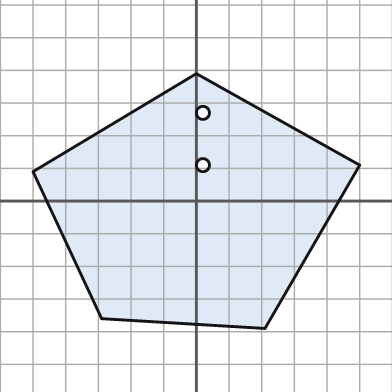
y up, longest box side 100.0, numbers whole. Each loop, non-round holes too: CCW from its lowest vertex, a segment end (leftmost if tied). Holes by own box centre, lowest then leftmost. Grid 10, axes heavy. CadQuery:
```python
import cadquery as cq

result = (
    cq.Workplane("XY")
    .moveTo(21.0, -39.0)
    .lineTo(50.0, 11.0)
    .lineTo(0.0, 39.0)
    .lineTo(-50.0, 9.0)
    .lineTo(-29.0, -36.0)
    .close()
    .moveTo(2.0, 11.0)
    .circle(2.0)
    .moveTo(2.0, 27.0)
    .circle(2.0)
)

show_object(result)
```